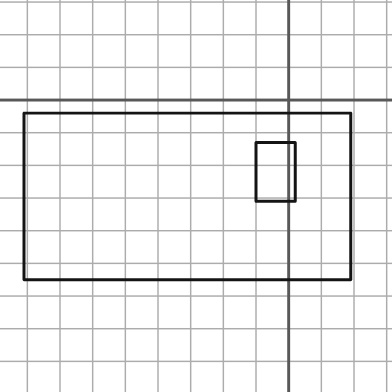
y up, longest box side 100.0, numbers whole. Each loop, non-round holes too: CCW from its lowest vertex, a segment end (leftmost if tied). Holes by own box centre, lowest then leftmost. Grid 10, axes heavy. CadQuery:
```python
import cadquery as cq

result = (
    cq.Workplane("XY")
    .moveTo(-81.0, -55.0)
    .lineTo(19.0, -55.0)
    .lineTo(19.0, -4.0)
    .lineTo(-81.0, -4.0)
    .close()
    .moveTo(-10.0, -31.0)
    .lineTo(2.0, -31.0)
    .lineTo(2.0, -13.0)
    .lineTo(-10.0, -13.0)
    .close()
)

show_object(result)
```